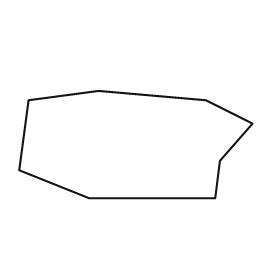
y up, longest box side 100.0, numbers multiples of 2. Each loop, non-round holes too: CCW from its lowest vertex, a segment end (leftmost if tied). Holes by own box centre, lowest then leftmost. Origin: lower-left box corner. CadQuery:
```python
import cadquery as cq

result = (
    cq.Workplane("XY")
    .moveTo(30.0, 0.0)
    .lineTo(84.0, 0.0)
    .lineTo(86.0, 16.0)
    .lineTo(100.0, 32.0)
    .lineTo(80.0, 42.0)
    .lineTo(34.0, 46.0)
    .lineTo(4.0, 42.0)
    .lineTo(0.0, 12.0)
    .close()
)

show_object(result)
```